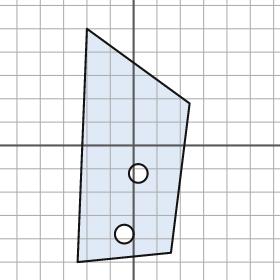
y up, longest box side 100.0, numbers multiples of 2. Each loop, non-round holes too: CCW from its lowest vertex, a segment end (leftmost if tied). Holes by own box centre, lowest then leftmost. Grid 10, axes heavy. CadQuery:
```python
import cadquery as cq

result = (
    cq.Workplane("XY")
    .moveTo(-24.0, -50.0)
    .lineTo(16.0, -46.0)
    .lineTo(24.0, 18.0)
    .lineTo(-20.0, 50.0)
    .close()
    .moveTo(-4.0, -38.0)
    .circle(4.0)
    .moveTo(2.0, -12.0)
    .circle(4.0)
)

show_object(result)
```